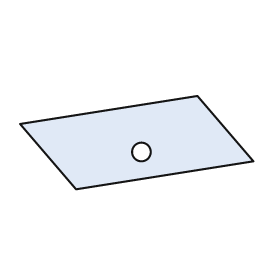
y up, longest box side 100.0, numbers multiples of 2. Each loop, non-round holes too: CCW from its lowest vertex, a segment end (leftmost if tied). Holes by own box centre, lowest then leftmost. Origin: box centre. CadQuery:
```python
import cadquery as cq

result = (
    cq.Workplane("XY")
    .moveTo(-26.0, -20.0)
    .lineTo(50.0, -8.0)
    .lineTo(26.0, 20.0)
    .lineTo(-50.0, 8.0)
    .close()
    .moveTo(2.0, -4.0)
    .circle(4.0)
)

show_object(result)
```